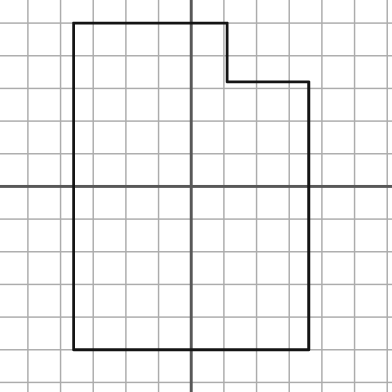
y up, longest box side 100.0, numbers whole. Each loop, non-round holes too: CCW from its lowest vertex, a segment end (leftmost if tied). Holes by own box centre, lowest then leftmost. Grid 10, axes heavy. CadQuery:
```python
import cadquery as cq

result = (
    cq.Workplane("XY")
    .moveTo(-36.0, -50.0)
    .lineTo(36.0, -50.0)
    .lineTo(36.0, 32.0)
    .lineTo(11.0, 32.0)
    .lineTo(11.0, 50.0)
    .lineTo(-36.0, 50.0)
    .close()
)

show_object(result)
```